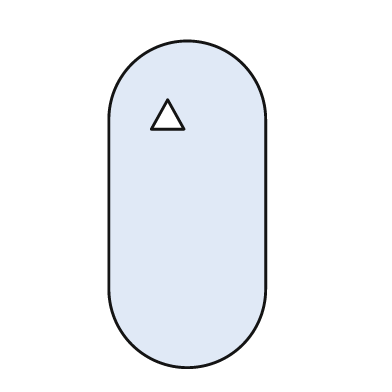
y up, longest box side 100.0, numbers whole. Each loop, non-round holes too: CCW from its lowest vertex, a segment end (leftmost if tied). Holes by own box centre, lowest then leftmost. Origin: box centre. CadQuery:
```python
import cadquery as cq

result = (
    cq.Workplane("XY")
    .moveTo(-24.0, -26.0)
    .threePointArc((0.0, -50.0), (24.0, -26.0))
    .lineTo(24.0, 26.0)
    .threePointArc((0.0, 50.0), (-24.0, 26.0))
    .close()
    .moveTo(-11.0, 23.0)
    .lineTo(-1.0, 23.0)
    .lineTo(-6.0, 32.0)
    .close()
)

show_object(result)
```